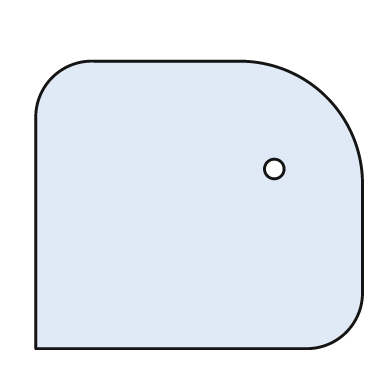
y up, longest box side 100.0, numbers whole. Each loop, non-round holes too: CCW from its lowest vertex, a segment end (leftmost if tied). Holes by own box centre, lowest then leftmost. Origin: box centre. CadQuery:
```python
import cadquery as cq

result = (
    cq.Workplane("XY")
    .moveTo(-50.0, -44.0)
    .lineTo(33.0, -44.0)
    .threePointArc((45.0, -39.0), (50.0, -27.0))
    .lineTo(50.0, 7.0)
    .threePointArc((39.0, 33.0), (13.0, 44.0))
    .lineTo(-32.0, 44.0)
    .threePointArc((-45.0, 39.0), (-50.0, 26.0))
    .close()
    .moveTo(23.0, 11.0)
    .circle(3.0)
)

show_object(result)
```